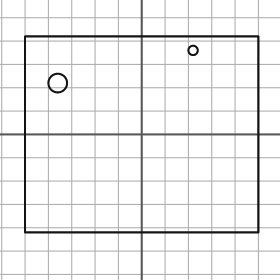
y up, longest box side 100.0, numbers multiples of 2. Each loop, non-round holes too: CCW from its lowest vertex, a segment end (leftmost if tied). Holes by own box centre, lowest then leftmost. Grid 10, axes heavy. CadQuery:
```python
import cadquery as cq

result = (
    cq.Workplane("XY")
    .moveTo(-50.0, -42.0)
    .lineTo(50.0, -42.0)
    .lineTo(50.0, 42.0)
    .lineTo(-50.0, 42.0)
    .close()
    .moveTo(-36.0, 22.0)
    .circle(4.0)
    .moveTo(22.0, 36.0)
    .circle(2.0)
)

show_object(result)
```